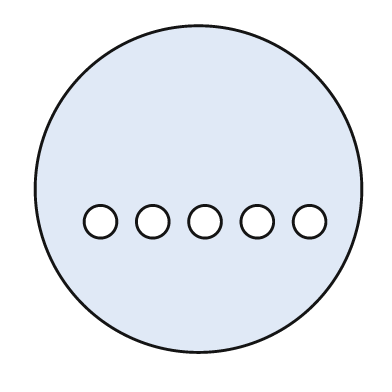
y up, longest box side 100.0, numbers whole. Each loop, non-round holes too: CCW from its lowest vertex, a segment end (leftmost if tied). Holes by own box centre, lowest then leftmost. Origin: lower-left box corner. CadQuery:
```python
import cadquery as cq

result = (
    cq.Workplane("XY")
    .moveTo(50.0, 50.0)
    .circle(50.0)
    .moveTo(20.0, 40.0)
    .circle(5.0)
    .moveTo(36.0, 40.0)
    .circle(5.0)
    .moveTo(52.0, 40.0)
    .circle(5.0)
    .moveTo(68.0, 40.0)
    .circle(5.0)
    .moveTo(84.0, 40.0)
    .circle(5.0)
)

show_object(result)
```